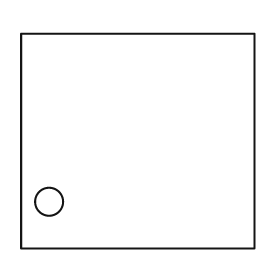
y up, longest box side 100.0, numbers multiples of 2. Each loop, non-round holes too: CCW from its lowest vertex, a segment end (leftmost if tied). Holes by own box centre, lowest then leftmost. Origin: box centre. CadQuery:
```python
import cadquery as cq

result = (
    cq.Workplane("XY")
    .moveTo(-50.0, -46.0)
    .lineTo(50.0, -46.0)
    .lineTo(50.0, 46.0)
    .lineTo(-50.0, 46.0)
    .close()
    .moveTo(-38.0, -26.0)
    .circle(6.0)
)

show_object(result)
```